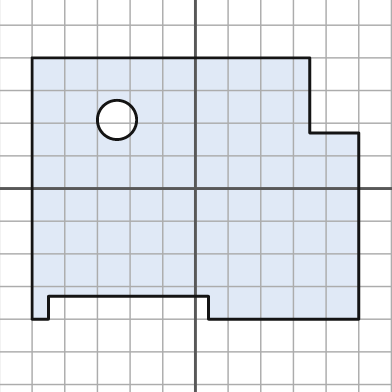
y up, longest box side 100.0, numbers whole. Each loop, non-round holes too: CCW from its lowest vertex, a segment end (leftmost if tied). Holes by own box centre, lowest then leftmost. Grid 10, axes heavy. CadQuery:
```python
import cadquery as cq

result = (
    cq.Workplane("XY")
    .moveTo(-50.0, -40.0)
    .lineTo(-45.0, -40.0)
    .lineTo(-45.0, -33.0)
    .lineTo(4.0, -33.0)
    .lineTo(4.0, -40.0)
    .lineTo(50.0, -40.0)
    .lineTo(50.0, 17.0)
    .lineTo(35.0, 17.0)
    .lineTo(35.0, 40.0)
    .lineTo(-50.0, 40.0)
    .close()
    .moveTo(-24.0, 21.0)
    .circle(6.0)
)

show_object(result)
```